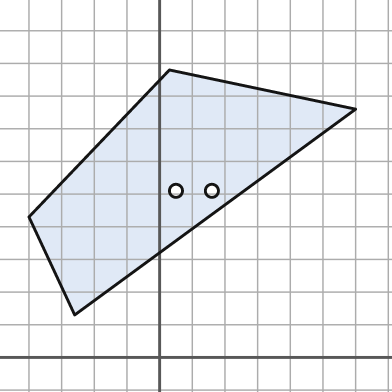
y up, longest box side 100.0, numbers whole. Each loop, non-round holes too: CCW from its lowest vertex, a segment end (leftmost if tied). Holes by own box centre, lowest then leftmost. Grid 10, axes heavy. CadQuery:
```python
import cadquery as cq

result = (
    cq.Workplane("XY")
    .moveTo(-26.0, 13.0)
    .lineTo(60.0, 76.0)
    .lineTo(3.0, 88.0)
    .lineTo(-40.0, 43.0)
    .close()
    .moveTo(5.0, 51.0)
    .circle(2.0)
    .moveTo(16.0, 51.0)
    .circle(2.0)
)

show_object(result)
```